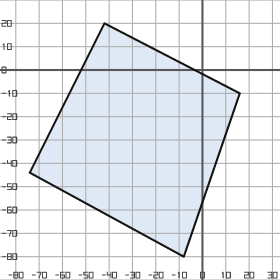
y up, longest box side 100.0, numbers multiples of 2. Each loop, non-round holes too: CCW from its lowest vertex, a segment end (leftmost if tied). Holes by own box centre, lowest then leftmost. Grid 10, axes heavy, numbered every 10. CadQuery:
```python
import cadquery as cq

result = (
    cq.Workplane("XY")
    .moveTo(-8.0, -80.0)
    .lineTo(16.0, -10.0)
    .lineTo(-42.0, 20.0)
    .lineTo(-74.0, -44.0)
    .close()
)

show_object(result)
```